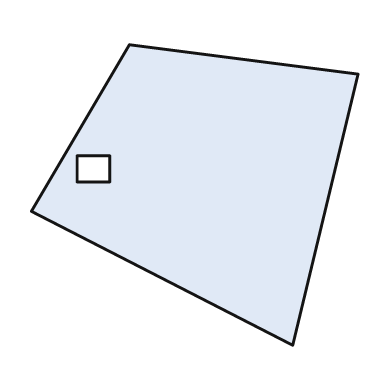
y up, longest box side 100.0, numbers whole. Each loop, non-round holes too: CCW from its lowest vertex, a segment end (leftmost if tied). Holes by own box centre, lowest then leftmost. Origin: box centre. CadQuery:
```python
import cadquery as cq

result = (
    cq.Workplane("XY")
    .moveTo(30.0, -46.0)
    .lineTo(50.0, 37.0)
    .lineTo(-20.0, 46.0)
    .lineTo(-50.0, -5.0)
    .close()
    .moveTo(-36.0, 4.0)
    .lineTo(-26.0, 4.0)
    .lineTo(-26.0, 12.0)
    .lineTo(-36.0, 12.0)
    .close()
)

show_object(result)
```